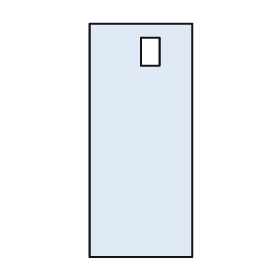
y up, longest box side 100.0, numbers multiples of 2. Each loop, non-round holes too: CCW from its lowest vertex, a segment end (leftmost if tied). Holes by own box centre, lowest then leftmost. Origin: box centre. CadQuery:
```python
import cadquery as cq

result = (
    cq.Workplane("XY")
    .moveTo(-22.0, -50.0)
    .lineTo(22.0, -50.0)
    .lineTo(22.0, 50.0)
    .lineTo(-22.0, 50.0)
    .close()
    .moveTo(0.0, 32.0)
    .lineTo(8.0, 32.0)
    .lineTo(8.0, 44.0)
    .lineTo(0.0, 44.0)
    .close()
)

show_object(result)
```